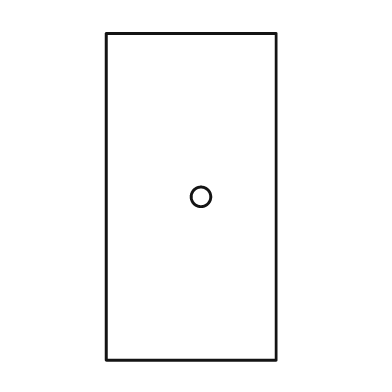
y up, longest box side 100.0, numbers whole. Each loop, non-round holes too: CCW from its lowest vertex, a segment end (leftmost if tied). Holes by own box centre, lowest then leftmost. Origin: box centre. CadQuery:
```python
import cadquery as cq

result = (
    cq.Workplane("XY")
    .moveTo(-26.0, -50.0)
    .lineTo(26.0, -50.0)
    .lineTo(26.0, 50.0)
    .lineTo(-26.0, 50.0)
    .close()
    .moveTo(3.0, 0.0)
    .circle(3.0)
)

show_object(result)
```